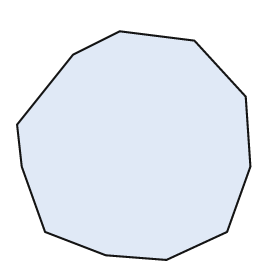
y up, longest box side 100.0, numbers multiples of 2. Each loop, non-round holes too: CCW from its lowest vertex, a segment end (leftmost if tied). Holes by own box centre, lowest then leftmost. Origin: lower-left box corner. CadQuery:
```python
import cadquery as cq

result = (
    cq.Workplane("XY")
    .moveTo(64.0, 0.0)
    .lineTo(90.0, 12.0)
    .lineTo(100.0, 40.0)
    .lineTo(98.0, 70.0)
    .lineTo(76.0, 94.0)
    .lineTo(44.0, 98.0)
    .lineTo(24.0, 88.0)
    .lineTo(0.0, 58.0)
    .lineTo(2.0, 40.0)
    .lineTo(12.0, 12.0)
    .lineTo(38.0, 2.0)
    .close()
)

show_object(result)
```